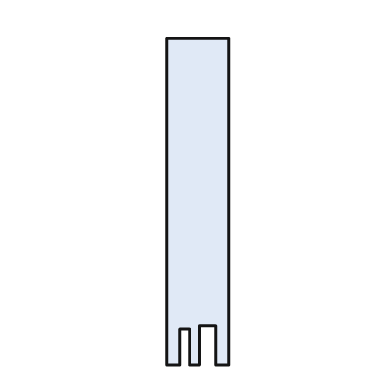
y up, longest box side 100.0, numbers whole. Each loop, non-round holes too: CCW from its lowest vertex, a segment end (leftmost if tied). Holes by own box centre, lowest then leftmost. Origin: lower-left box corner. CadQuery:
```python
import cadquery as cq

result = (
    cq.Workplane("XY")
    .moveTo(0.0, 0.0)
    .lineTo(4.0, 0.0)
    .lineTo(4.0, 11.0)
    .lineTo(7.0, 11.0)
    .lineTo(7.0, 0.0)
    .lineTo(10.0, 0.0)
    .lineTo(10.0, 12.0)
    .lineTo(15.0, 12.0)
    .lineTo(15.0, 0.0)
    .lineTo(19.0, 0.0)
    .lineTo(19.0, 100.0)
    .lineTo(0.0, 100.0)
    .close()
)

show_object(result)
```